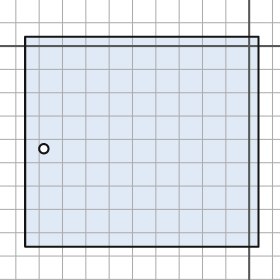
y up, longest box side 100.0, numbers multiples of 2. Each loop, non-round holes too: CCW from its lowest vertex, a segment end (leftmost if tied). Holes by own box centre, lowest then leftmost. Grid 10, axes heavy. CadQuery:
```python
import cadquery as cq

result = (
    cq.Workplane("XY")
    .moveTo(-96.0, -86.0)
    .lineTo(4.0, -86.0)
    .lineTo(4.0, 4.0)
    .lineTo(-96.0, 4.0)
    .close()
    .moveTo(-88.0, -44.0)
    .circle(2.0)
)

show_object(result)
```